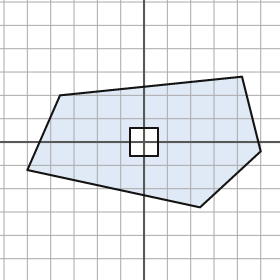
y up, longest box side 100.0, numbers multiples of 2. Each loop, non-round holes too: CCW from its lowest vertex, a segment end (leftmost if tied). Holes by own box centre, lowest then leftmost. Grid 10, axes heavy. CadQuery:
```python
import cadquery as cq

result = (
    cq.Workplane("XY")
    .moveTo(24.0, -28.0)
    .lineTo(50.0, -4.0)
    .lineTo(42.0, 28.0)
    .lineTo(-36.0, 20.0)
    .lineTo(-50.0, -12.0)
    .close()
    .moveTo(-6.0, -6.0)
    .lineTo(6.0, -6.0)
    .lineTo(6.0, 6.0)
    .lineTo(-6.0, 6.0)
    .close()
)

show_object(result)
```